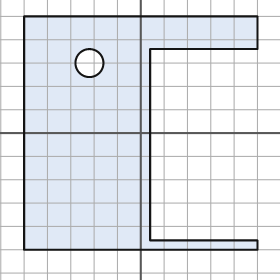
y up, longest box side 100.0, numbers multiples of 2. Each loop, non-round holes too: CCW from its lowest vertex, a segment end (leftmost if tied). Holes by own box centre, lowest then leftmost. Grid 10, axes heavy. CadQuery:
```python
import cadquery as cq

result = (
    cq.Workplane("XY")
    .moveTo(-50.0, -50.0)
    .lineTo(50.0, -50.0)
    .lineTo(50.0, -46.0)
    .lineTo(4.0, -46.0)
    .lineTo(4.0, 36.0)
    .lineTo(50.0, 36.0)
    .lineTo(50.0, 50.0)
    .lineTo(-50.0, 50.0)
    .close()
    .moveTo(-22.0, 30.0)
    .circle(6.0)
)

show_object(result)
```